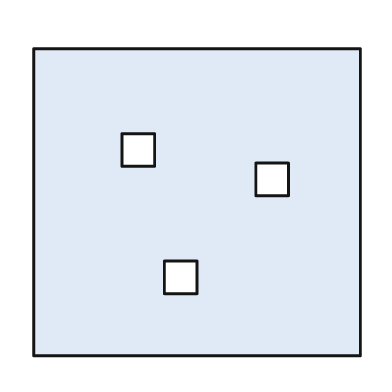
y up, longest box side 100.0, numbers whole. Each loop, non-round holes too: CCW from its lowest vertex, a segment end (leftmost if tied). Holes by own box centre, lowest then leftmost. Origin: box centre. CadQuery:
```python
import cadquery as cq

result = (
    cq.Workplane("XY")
    .moveTo(-50.0, -47.0)
    .lineTo(50.0, -47.0)
    .lineTo(50.0, 47.0)
    .lineTo(-50.0, 47.0)
    .close()
    .moveTo(-10.0, -28.0)
    .lineTo(0.0, -28.0)
    .lineTo(0.0, -18.0)
    .lineTo(-10.0, -18.0)
    .close()
    .moveTo(18.0, 2.0)
    .lineTo(28.0, 2.0)
    .lineTo(28.0, 12.0)
    .lineTo(18.0, 12.0)
    .close()
    .moveTo(-23.0, 11.0)
    .lineTo(-13.0, 11.0)
    .lineTo(-13.0, 21.0)
    .lineTo(-23.0, 21.0)
    .close()
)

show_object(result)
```